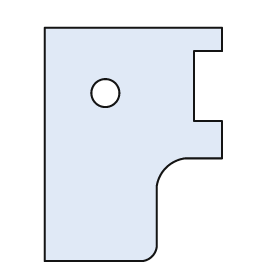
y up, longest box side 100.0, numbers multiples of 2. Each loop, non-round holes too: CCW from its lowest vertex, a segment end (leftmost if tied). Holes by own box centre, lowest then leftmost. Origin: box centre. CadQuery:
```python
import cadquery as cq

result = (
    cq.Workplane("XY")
    .moveTo(-38.0, -50.0)
    .lineTo(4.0, -50.0)
    .threePointArc((8.0, -48.0), (10.0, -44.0))
    .lineTo(10.0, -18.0)
    .threePointArc((14.0, -10.0), (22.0, -6.0))
    .lineTo(38.0, -6.0)
    .lineTo(38.0, 10.0)
    .lineTo(26.0, 10.0)
    .lineTo(26.0, 40.0)
    .lineTo(38.0, 40.0)
    .lineTo(38.0, 50.0)
    .lineTo(-38.0, 50.0)
    .close()
    .moveTo(-12.0, 22.0)
    .circle(6.0)
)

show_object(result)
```